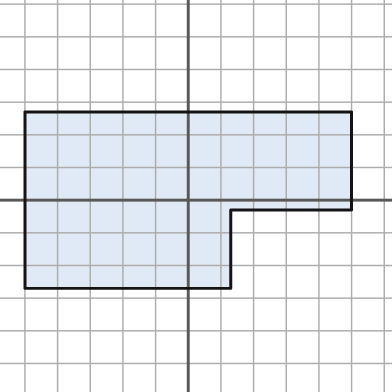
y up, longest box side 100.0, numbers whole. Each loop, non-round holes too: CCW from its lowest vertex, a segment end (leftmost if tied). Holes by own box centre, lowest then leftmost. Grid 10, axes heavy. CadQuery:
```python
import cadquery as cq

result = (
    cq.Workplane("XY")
    .moveTo(-50.0, -27.0)
    .lineTo(13.0, -27.0)
    .lineTo(13.0, -3.0)
    .lineTo(50.0, -3.0)
    .lineTo(50.0, 27.0)
    .lineTo(-50.0, 27.0)
    .close()
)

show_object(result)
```